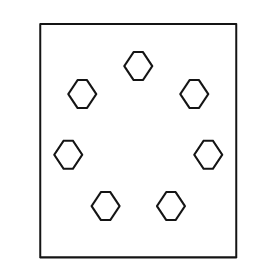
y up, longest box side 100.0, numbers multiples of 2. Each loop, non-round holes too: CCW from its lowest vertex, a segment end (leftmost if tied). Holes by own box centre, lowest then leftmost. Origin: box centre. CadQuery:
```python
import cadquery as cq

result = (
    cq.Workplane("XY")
    .moveTo(-42.0, -50.0)
    .lineTo(42.0, -50.0)
    .lineTo(42.0, 50.0)
    .lineTo(-42.0, 50.0)
    .close()
    .moveTo(-16.0, -34.0)
    .lineTo(-12.0, -34.0)
    .lineTo(-8.0, -28.0)
    .lineTo(-12.0, -22.0)
    .lineTo(-16.0, -22.0)
    .lineTo(-20.0, -28.0)
    .close()
    .moveTo(12.0, -34.0)
    .lineTo(16.0, -34.0)
    .lineTo(20.0, -28.0)
    .lineTo(16.0, -22.0)
    .lineTo(12.0, -22.0)
    .lineTo(8.0, -28.0)
    .close()
    .moveTo(-32.0, -12.0)
    .lineTo(-28.0, -12.0)
    .lineTo(-24.0, -6.0)
    .lineTo(-28.0, 0.0)
    .lineTo(-32.0, 0.0)
    .lineTo(-36.0, -6.0)
    .close()
    .moveTo(28.0, -12.0)
    .lineTo(32.0, -12.0)
    .lineTo(36.0, -6.0)
    .lineTo(32.0, 0.0)
    .lineTo(28.0, 0.0)
    .lineTo(24.0, -6.0)
    .close()
    .moveTo(-26.0, 14.0)
    .lineTo(-22.0, 14.0)
    .lineTo(-18.0, 20.0)
    .lineTo(-22.0, 26.0)
    .lineTo(-26.0, 26.0)
    .lineTo(-30.0, 20.0)
    .close()
    .moveTo(22.0, 14.0)
    .lineTo(26.0, 14.0)
    .lineTo(30.0, 20.0)
    .lineTo(26.0, 26.0)
    .lineTo(22.0, 26.0)
    .lineTo(18.0, 20.0)
    .close()
    .moveTo(-2.0, 26.0)
    .lineTo(2.0, 26.0)
    .lineTo(6.0, 32.0)
    .lineTo(2.0, 38.0)
    .lineTo(-2.0, 38.0)
    .lineTo(-6.0, 32.0)
    .close()
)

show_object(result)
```